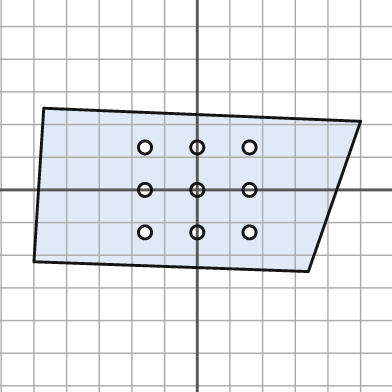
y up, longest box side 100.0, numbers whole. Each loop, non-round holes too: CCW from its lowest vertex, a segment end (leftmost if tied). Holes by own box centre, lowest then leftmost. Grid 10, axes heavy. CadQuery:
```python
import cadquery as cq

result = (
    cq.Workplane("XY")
    .moveTo(34.0, -25.0)
    .lineTo(50.0, 21.0)
    .lineTo(-47.0, 25.0)
    .lineTo(-50.0, -22.0)
    .close()
    .moveTo(-16.0, -13.0)
    .circle(2.0)
    .moveTo(0.0, -13.0)
    .circle(2.0)
    .moveTo(16.0, -13.0)
    .circle(2.0)
    .moveTo(-16.0, 0.0)
    .circle(2.0)
    .moveTo(0.0, 0.0)
    .circle(2.0)
    .moveTo(16.0, 0.0)
    .circle(2.0)
    .moveTo(-16.0, 13.0)
    .circle(2.0)
    .moveTo(0.0, 13.0)
    .circle(2.0)
    .moveTo(16.0, 13.0)
    .circle(2.0)
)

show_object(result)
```